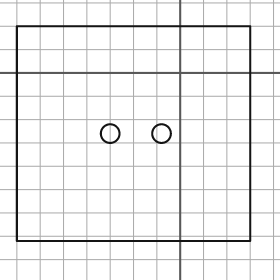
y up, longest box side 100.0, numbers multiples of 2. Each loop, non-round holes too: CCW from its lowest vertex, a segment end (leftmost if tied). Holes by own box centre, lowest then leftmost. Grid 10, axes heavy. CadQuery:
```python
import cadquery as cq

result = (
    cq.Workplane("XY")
    .moveTo(-70.0, -72.0)
    .lineTo(30.0, -72.0)
    .lineTo(30.0, 20.0)
    .lineTo(-70.0, 20.0)
    .close()
    .moveTo(-30.0, -26.0)
    .circle(4.0)
    .moveTo(-8.0, -26.0)
    .circle(4.0)
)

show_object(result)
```